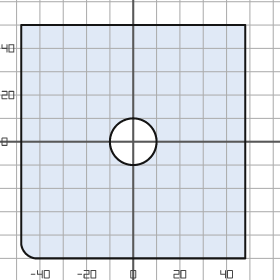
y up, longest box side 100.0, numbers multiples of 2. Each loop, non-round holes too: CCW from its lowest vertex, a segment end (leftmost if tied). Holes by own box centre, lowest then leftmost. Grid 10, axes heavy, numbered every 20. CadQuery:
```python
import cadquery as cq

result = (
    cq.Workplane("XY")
    .moveTo(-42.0, -50.0)
    .lineTo(48.0, -50.0)
    .lineTo(48.0, 50.0)
    .lineTo(-48.0, 50.0)
    .lineTo(-48.0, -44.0)
    .threePointArc((-46.0, -48.0), (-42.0, -50.0))
    .close()
    .moveTo(0.0, 0.0)
    .circle(10.0)
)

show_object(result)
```